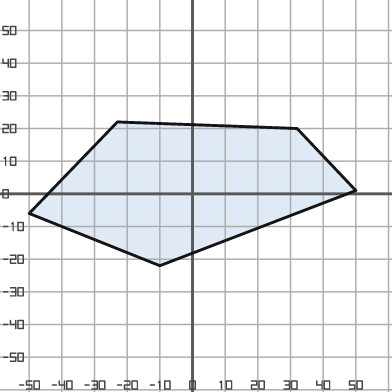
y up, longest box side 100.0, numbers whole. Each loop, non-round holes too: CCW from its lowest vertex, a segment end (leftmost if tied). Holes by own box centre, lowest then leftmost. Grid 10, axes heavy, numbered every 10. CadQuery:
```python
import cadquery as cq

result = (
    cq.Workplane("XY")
    .moveTo(-10.0, -22.0)
    .lineTo(50.0, 1.0)
    .lineTo(32.0, 20.0)
    .lineTo(-23.0, 22.0)
    .lineTo(-50.0, -6.0)
    .close()
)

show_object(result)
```